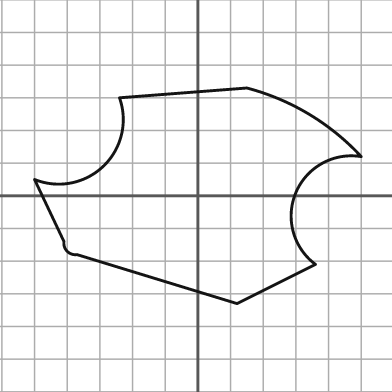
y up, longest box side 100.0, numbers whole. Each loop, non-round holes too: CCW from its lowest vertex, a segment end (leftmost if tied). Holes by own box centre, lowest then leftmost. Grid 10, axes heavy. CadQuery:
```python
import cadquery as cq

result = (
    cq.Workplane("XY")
    .moveTo(12.0, -33.0)
    .lineTo(36.0, -21.0)
    .threePointArc((30.0, 1.0), (50.0, 12.0))
    .threePointArc((34.0, 25.0), (15.0, 33.0))
    .lineTo(-24.0, 30.0)
    .threePointArc((-29.0, 9.0), (-50.0, 5.0))
    .lineTo(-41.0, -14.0)
    .threePointArc((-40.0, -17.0), (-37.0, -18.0))
    .close()
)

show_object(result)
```